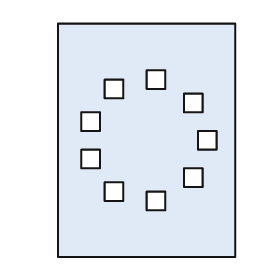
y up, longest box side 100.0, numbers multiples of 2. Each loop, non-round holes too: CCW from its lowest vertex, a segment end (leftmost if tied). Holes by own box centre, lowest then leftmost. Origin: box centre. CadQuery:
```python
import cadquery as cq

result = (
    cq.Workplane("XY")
    .moveTo(-38.0, -50.0)
    .lineTo(38.0, -50.0)
    .lineTo(38.0, 50.0)
    .lineTo(-38.0, 50.0)
    .close()
    .moveTo(0.0, -30.0)
    .lineTo(8.0, -30.0)
    .lineTo(8.0, -22.0)
    .lineTo(0.0, -22.0)
    .close()
    .moveTo(-18.0, -26.0)
    .lineTo(-10.0, -26.0)
    .lineTo(-10.0, -18.0)
    .lineTo(-18.0, -18.0)
    .close()
    .moveTo(16.0, -20.0)
    .lineTo(24.0, -20.0)
    .lineTo(24.0, -12.0)
    .lineTo(16.0, -12.0)
    .close()
    .moveTo(-28.0, -12.0)
    .lineTo(-20.0, -12.0)
    .lineTo(-20.0, -4.0)
    .lineTo(-28.0, -4.0)
    .close()
    .moveTo(22.0, -4.0)
    .lineTo(30.0, -4.0)
    .lineTo(30.0, 4.0)
    .lineTo(22.0, 4.0)
    .close()
    .moveTo(-28.0, 4.0)
    .lineTo(-20.0, 4.0)
    .lineTo(-20.0, 12.0)
    .lineTo(-28.0, 12.0)
    .close()
    .moveTo(16.0, 12.0)
    .lineTo(24.0, 12.0)
    .lineTo(24.0, 20.0)
    .lineTo(16.0, 20.0)
    .close()
    .moveTo(-18.0, 18.0)
    .lineTo(-10.0, 18.0)
    .lineTo(-10.0, 26.0)
    .lineTo(-18.0, 26.0)
    .close()
    .moveTo(0.0, 22.0)
    .lineTo(8.0, 22.0)
    .lineTo(8.0, 30.0)
    .lineTo(0.0, 30.0)
    .close()
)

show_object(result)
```